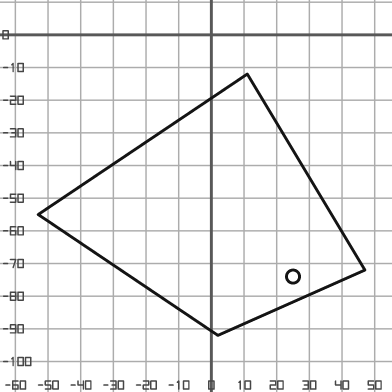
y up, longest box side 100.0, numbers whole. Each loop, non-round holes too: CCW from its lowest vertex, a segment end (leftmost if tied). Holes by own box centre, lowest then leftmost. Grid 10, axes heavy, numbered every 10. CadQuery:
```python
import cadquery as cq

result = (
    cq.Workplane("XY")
    .moveTo(2.0, -92.0)
    .lineTo(47.0, -72.0)
    .lineTo(11.0, -12.0)
    .lineTo(-53.0, -55.0)
    .close()
    .moveTo(25.0, -74.0)
    .circle(2.0)
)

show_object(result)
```